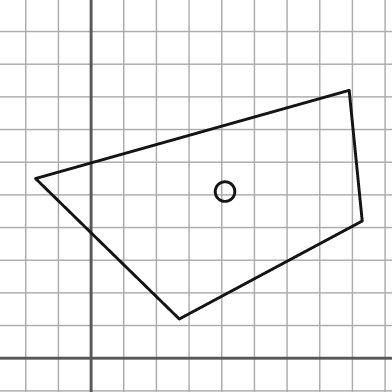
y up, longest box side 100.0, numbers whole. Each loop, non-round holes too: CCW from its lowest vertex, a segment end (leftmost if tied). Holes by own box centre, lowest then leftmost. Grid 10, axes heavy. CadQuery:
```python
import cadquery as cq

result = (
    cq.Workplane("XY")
    .moveTo(27.0, 12.0)
    .lineTo(83.0, 42.0)
    .lineTo(79.0, 82.0)
    .lineTo(-17.0, 55.0)
    .close()
    .moveTo(41.0, 51.0)
    .circle(3.0)
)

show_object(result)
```